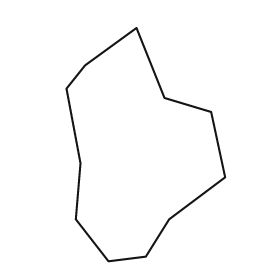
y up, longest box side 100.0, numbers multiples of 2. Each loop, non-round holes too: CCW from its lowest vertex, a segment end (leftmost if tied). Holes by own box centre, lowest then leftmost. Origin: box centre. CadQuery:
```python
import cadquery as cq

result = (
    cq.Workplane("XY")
    .moveTo(-16.0, -50.0)
    .lineTo(0.0, -48.0)
    .lineTo(10.0, -32.0)
    .lineTo(34.0, -14.0)
    .lineTo(28.0, 14.0)
    .lineTo(8.0, 20.0)
    .lineTo(-4.0, 50.0)
    .lineTo(-26.0, 34.0)
    .lineTo(-34.0, 24.0)
    .lineTo(-28.0, -8.0)
    .lineTo(-30.0, -32.0)
    .close()
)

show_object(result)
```